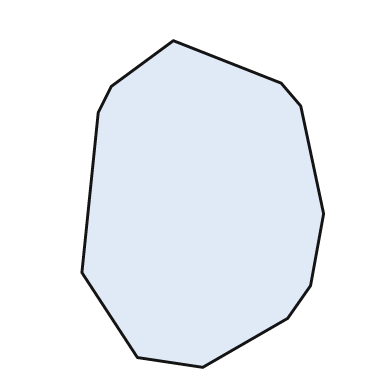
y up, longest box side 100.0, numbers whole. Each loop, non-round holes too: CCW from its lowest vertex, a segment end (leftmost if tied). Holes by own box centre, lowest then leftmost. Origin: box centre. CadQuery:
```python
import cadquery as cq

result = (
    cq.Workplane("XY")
    .moveTo(0.0, -50.0)
    .lineTo(26.0, -35.0)
    .lineTo(33.0, -25.0)
    .lineTo(37.0, -3.0)
    .lineTo(30.0, 30.0)
    .lineTo(24.0, 37.0)
    .lineTo(-9.0, 50.0)
    .lineTo(-28.0, 36.0)
    .lineTo(-32.0, 28.0)
    .lineTo(-37.0, -21.0)
    .lineTo(-20.0, -47.0)
    .close()
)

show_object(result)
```